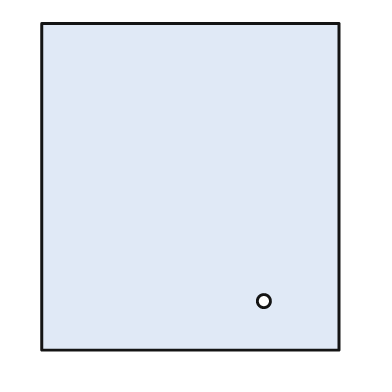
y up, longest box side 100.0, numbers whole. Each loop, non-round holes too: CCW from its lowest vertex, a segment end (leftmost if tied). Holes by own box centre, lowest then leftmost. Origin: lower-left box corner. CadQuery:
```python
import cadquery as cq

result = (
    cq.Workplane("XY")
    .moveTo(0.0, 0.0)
    .lineTo(91.0, 0.0)
    .lineTo(91.0, 100.0)
    .lineTo(0.0, 100.0)
    .close()
    .moveTo(68.0, 15.0)
    .circle(2.0)
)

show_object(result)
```